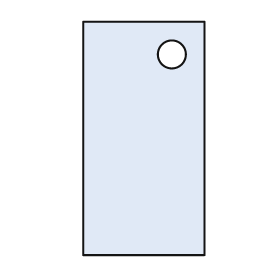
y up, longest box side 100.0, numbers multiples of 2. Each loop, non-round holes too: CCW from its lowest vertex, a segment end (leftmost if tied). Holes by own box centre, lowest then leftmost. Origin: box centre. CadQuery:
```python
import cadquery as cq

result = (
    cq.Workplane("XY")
    .moveTo(-26.0, -50.0)
    .lineTo(26.0, -50.0)
    .lineTo(26.0, 50.0)
    .lineTo(-26.0, 50.0)
    .close()
    .moveTo(12.0, 36.0)
    .circle(6.0)
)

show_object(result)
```